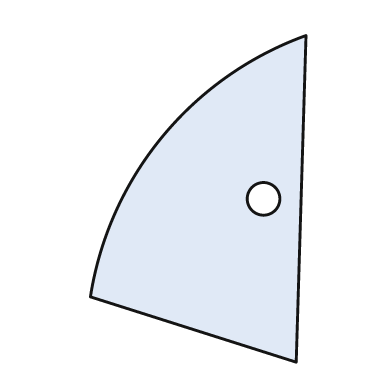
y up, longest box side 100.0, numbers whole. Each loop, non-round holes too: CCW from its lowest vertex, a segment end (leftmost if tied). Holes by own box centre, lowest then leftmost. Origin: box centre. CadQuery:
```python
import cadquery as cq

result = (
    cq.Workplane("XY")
    .moveTo(30.0, -50.0)
    .lineTo(33.0, 50.0)
    .threePointArc((-11.0, 19.0), (-33.0, -30.0))
    .close()
    .moveTo(20.0, 0.0)
    .circle(5.0)
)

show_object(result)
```